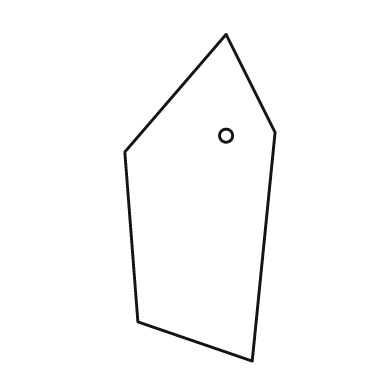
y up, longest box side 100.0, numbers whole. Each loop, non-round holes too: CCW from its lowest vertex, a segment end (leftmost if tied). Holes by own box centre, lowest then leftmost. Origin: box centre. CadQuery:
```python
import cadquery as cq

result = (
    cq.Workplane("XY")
    .moveTo(16.0, -50.0)
    .lineTo(23.0, 20.0)
    .lineTo(8.0, 50.0)
    .lineTo(-23.0, 14.0)
    .lineTo(-19.0, -38.0)
    .close()
    .moveTo(8.0, 19.0)
    .circle(2.0)
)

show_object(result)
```